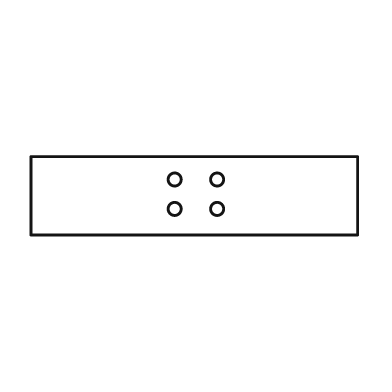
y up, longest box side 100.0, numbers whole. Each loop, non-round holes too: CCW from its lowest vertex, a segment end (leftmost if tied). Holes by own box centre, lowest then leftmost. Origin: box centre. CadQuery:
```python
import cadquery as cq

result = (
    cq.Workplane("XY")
    .moveTo(-50.0, -12.0)
    .lineTo(50.0, -12.0)
    .lineTo(50.0, 12.0)
    .lineTo(-50.0, 12.0)
    .close()
    .moveTo(-6.0, -4.0)
    .circle(2.0)
    .moveTo(7.0, -4.0)
    .circle(2.0)
    .moveTo(-6.0, 5.0)
    .circle(2.0)
    .moveTo(7.0, 5.0)
    .circle(2.0)
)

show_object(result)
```